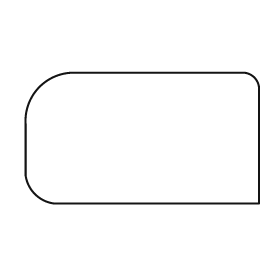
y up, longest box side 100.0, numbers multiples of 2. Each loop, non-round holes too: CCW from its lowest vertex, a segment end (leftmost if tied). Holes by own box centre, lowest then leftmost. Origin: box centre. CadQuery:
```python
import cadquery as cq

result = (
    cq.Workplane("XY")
    .moveTo(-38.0, -28.0)
    .lineTo(50.0, -28.0)
    .lineTo(50.0, 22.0)
    .threePointArc((48.0, 26.0), (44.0, 28.0))
    .lineTo(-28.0, 28.0)
    .threePointArc((-44.0, 22.0), (-50.0, 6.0))
    .lineTo(-50.0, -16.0)
    .threePointArc((-46.0, -24.0), (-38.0, -28.0))
    .close()
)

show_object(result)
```